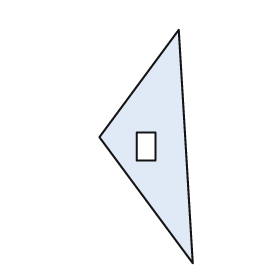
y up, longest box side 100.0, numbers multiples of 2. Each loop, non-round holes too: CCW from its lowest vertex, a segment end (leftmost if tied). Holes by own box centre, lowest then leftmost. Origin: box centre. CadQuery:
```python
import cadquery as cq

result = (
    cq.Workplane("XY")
    .moveTo(20.0, -50.0)
    .lineTo(14.0, 50.0)
    .lineTo(-20.0, 4.0)
    .close()
    .moveTo(-4.0, -6.0)
    .lineTo(4.0, -6.0)
    .lineTo(4.0, 6.0)
    .lineTo(-4.0, 6.0)
    .close()
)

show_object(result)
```